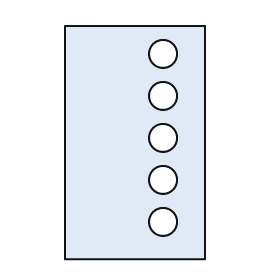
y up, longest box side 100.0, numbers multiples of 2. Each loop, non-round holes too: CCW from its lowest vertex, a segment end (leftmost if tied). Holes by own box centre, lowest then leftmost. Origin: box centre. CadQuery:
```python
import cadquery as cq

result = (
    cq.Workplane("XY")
    .moveTo(-30.0, -50.0)
    .lineTo(30.0, -50.0)
    .lineTo(30.0, 50.0)
    .lineTo(-30.0, 50.0)
    .close()
    .moveTo(12.0, -34.0)
    .circle(6.0)
    .moveTo(12.0, -16.0)
    .circle(6.0)
    .moveTo(12.0, 2.0)
    .circle(6.0)
    .moveTo(12.0, 20.0)
    .circle(6.0)
    .moveTo(12.0, 38.0)
    .circle(6.0)
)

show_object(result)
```